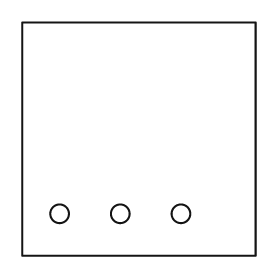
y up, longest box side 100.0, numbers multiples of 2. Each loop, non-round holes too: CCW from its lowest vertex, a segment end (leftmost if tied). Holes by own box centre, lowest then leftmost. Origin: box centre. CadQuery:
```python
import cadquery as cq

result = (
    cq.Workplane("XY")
    .moveTo(-50.0, -50.0)
    .lineTo(50.0, -50.0)
    .lineTo(50.0, 50.0)
    .lineTo(-50.0, 50.0)
    .close()
    .moveTo(-34.0, -32.0)
    .circle(4.0)
    .moveTo(-8.0, -32.0)
    .circle(4.0)
    .moveTo(18.0, -32.0)
    .circle(4.0)
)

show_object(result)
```